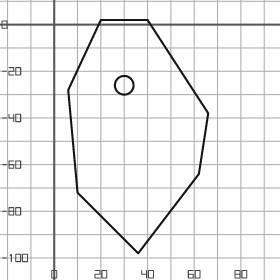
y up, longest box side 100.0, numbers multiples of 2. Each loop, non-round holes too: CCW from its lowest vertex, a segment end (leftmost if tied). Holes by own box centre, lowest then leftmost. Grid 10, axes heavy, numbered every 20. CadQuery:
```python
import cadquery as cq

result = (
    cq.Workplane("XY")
    .moveTo(36.0, -98.0)
    .lineTo(62.0, -64.0)
    .lineTo(66.0, -38.0)
    .lineTo(40.0, 2.0)
    .lineTo(20.0, 2.0)
    .lineTo(6.0, -28.0)
    .lineTo(10.0, -72.0)
    .close()
    .moveTo(30.0, -26.0)
    .circle(4.0)
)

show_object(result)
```